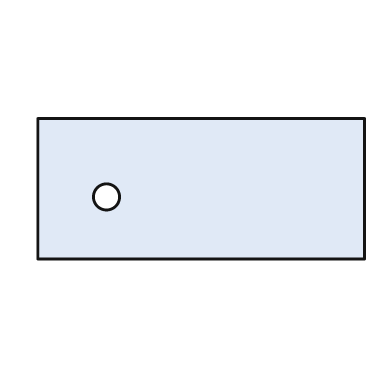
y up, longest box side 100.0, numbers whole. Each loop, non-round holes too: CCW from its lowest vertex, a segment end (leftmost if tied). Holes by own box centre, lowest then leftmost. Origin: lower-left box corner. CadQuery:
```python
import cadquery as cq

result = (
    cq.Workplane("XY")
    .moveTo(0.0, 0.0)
    .lineTo(100.0, 0.0)
    .lineTo(100.0, 43.0)
    .lineTo(0.0, 43.0)
    .close()
    .moveTo(21.0, 19.0)
    .circle(4.0)
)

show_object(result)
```